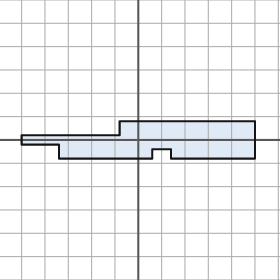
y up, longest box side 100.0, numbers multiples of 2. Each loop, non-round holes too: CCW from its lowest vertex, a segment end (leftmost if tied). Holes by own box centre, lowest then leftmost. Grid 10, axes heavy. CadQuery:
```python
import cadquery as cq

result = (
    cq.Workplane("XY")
    .moveTo(-34.0, -8.0)
    .lineTo(6.0, -8.0)
    .lineTo(6.0, -4.0)
    .lineTo(14.0, -4.0)
    .lineTo(14.0, -8.0)
    .lineTo(50.0, -8.0)
    .lineTo(50.0, 8.0)
    .lineTo(-8.0, 8.0)
    .lineTo(-8.0, 2.0)
    .lineTo(-50.0, 2.0)
    .lineTo(-50.0, -2.0)
    .lineTo(-34.0, -2.0)
    .close()
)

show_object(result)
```